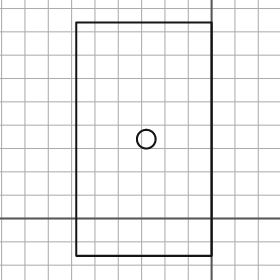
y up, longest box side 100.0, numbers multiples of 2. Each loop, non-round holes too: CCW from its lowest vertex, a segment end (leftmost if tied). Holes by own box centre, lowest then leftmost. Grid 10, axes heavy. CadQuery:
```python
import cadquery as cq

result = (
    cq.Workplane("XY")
    .moveTo(-58.0, -16.0)
    .lineTo(0.0, -16.0)
    .lineTo(0.0, 84.0)
    .lineTo(-58.0, 84.0)
    .close()
    .moveTo(-28.0, 34.0)
    .circle(4.0)
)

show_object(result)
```